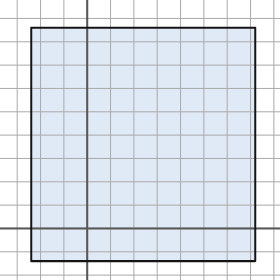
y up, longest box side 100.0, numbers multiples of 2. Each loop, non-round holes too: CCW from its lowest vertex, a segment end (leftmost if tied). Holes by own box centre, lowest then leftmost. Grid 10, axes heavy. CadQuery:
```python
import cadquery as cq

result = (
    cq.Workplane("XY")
    .moveTo(-24.0, -14.0)
    .lineTo(72.0, -14.0)
    .lineTo(72.0, 86.0)
    .lineTo(-24.0, 86.0)
    .close()
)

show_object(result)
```